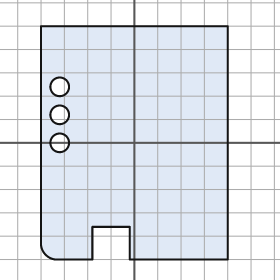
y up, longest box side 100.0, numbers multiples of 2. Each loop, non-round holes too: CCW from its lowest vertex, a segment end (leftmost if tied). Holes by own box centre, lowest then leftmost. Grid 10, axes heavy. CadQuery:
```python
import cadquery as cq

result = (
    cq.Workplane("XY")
    .moveTo(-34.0, -50.0)
    .lineTo(-18.0, -50.0)
    .lineTo(-18.0, -36.0)
    .lineTo(-2.0, -36.0)
    .lineTo(-2.0, -50.0)
    .lineTo(40.0, -50.0)
    .lineTo(40.0, 50.0)
    .lineTo(-40.0, 50.0)
    .lineTo(-40.0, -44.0)
    .threePointArc((-38.0, -48.0), (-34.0, -50.0))
    .close()
    .moveTo(-32.0, 0.0)
    .circle(4.0)
    .moveTo(-32.0, 12.0)
    .circle(4.0)
    .moveTo(-32.0, 24.0)
    .circle(4.0)
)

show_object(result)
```